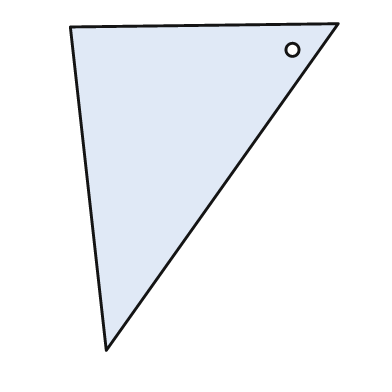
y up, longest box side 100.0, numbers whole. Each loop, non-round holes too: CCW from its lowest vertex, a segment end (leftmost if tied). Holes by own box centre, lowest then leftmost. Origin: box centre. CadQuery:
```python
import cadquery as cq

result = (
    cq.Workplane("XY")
    .moveTo(-30.0, -50.0)
    .lineTo(41.0, 50.0)
    .lineTo(-41.0, 49.0)
    .close()
    .moveTo(27.0, 42.0)
    .circle(2.0)
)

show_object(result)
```